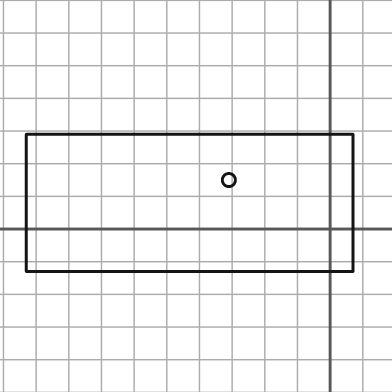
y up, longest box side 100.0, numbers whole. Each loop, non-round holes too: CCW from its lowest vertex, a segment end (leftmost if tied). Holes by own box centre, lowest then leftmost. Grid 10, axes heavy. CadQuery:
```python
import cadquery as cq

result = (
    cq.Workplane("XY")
    .moveTo(-93.0, -13.0)
    .lineTo(7.0, -13.0)
    .lineTo(7.0, 29.0)
    .lineTo(-93.0, 29.0)
    .close()
    .moveTo(-31.0, 15.0)
    .circle(2.0)
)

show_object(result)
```